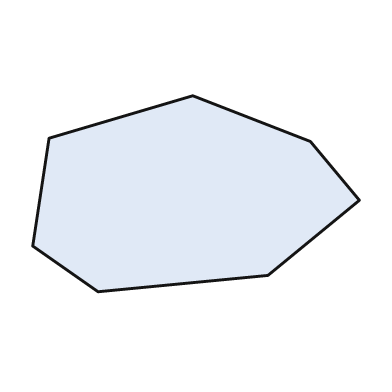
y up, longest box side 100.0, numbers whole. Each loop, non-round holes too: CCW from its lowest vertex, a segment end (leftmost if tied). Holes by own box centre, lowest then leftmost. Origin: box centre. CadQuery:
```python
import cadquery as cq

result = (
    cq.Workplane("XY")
    .moveTo(-30.0, -30.0)
    .lineTo(22.0, -25.0)
    .lineTo(50.0, -2.0)
    .lineTo(35.0, 16.0)
    .lineTo(-1.0, 30.0)
    .lineTo(-45.0, 17.0)
    .lineTo(-50.0, -16.0)
    .close()
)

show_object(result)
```